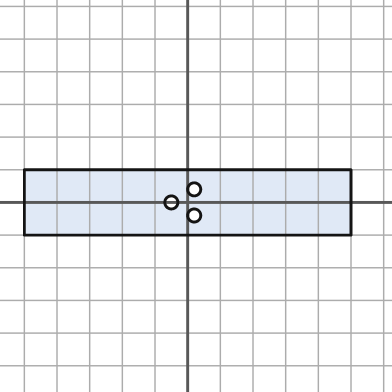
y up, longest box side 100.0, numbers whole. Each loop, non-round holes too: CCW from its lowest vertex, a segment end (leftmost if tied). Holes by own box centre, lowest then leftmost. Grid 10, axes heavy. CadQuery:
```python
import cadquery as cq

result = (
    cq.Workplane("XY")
    .moveTo(-50.0, -10.0)
    .lineTo(50.0, -10.0)
    .lineTo(50.0, 10.0)
    .lineTo(-50.0, 10.0)
    .close()
    .moveTo(2.0, -4.0)
    .circle(2.0)
    .moveTo(-5.0, 0.0)
    .circle(2.0)
    .moveTo(2.0, 4.0)
    .circle(2.0)
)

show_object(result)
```